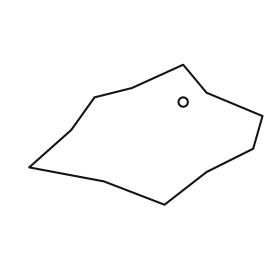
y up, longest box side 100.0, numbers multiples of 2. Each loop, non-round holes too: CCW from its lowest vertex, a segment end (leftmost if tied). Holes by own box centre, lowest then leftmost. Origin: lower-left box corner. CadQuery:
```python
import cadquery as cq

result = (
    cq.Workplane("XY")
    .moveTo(58.0, 0.0)
    .lineTo(76.0, 14.0)
    .lineTo(96.0, 24.0)
    .lineTo(100.0, 38.0)
    .lineTo(76.0, 48.0)
    .lineTo(66.0, 60.0)
    .lineTo(44.0, 50.0)
    .lineTo(28.0, 46.0)
    .lineTo(18.0, 32.0)
    .lineTo(0.0, 16.0)
    .lineTo(32.0, 10.0)
    .close()
    .moveTo(66.0, 44.0)
    .circle(2.0)
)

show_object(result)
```